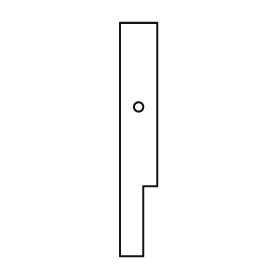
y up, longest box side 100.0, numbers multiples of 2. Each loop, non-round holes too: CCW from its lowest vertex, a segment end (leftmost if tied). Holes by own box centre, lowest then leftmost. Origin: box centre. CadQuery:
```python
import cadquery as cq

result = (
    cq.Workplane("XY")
    .moveTo(-8.0, -50.0)
    .lineTo(2.0, -50.0)
    .lineTo(2.0, -20.0)
    .lineTo(8.0, -20.0)
    .lineTo(8.0, 50.0)
    .lineTo(-8.0, 50.0)
    .close()
    .moveTo(0.0, 14.0)
    .circle(2.0)
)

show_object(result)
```